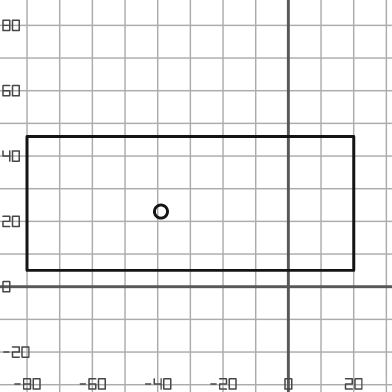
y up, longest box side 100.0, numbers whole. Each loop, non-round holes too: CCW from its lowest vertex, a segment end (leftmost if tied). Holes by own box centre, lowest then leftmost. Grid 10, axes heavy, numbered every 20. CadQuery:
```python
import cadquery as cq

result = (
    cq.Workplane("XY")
    .moveTo(-80.0, 5.0)
    .lineTo(20.0, 5.0)
    .lineTo(20.0, 46.0)
    .lineTo(-80.0, 46.0)
    .close()
    .moveTo(-39.0, 23.0)
    .circle(2.0)
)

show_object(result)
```